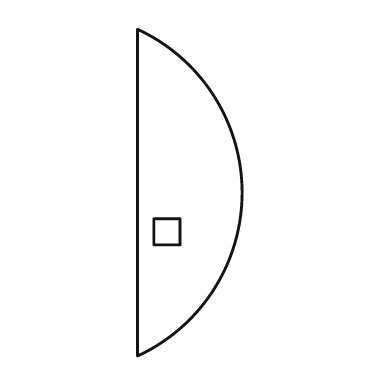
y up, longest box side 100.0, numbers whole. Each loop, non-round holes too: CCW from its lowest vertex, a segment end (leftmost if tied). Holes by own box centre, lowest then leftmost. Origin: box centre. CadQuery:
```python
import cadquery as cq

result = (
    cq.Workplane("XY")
    .moveTo(-16.0, -50.0)
    .threePointArc((16.0, 0.0), (-16.0, 50.0))
    .close()
    .moveTo(-11.0, -16.0)
    .lineTo(-3.0, -16.0)
    .lineTo(-3.0, -8.0)
    .lineTo(-11.0, -8.0)
    .close()
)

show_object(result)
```